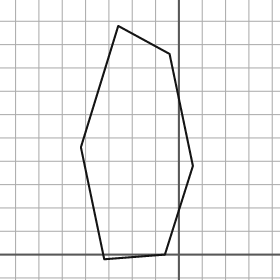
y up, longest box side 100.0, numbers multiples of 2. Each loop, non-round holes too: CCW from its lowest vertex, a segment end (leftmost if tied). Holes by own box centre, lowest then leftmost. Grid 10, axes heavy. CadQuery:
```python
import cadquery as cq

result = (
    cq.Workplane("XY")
    .moveTo(-32.0, -2.0)
    .lineTo(-6.0, 0.0)
    .lineTo(6.0, 38.0)
    .lineTo(-4.0, 86.0)
    .lineTo(-26.0, 98.0)
    .lineTo(-42.0, 46.0)
    .close()
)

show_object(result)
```